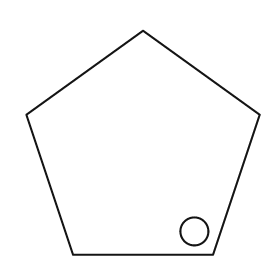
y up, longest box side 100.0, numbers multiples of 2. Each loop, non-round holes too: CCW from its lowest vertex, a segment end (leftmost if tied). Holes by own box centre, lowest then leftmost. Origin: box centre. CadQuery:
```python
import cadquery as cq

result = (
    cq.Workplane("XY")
    .moveTo(-30.0, -48.0)
    .lineTo(30.0, -48.0)
    .lineTo(50.0, 12.0)
    .lineTo(0.0, 48.0)
    .lineTo(-50.0, 12.0)
    .close()
    .moveTo(22.0, -38.0)
    .circle(6.0)
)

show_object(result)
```